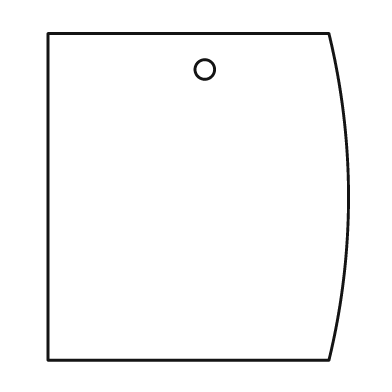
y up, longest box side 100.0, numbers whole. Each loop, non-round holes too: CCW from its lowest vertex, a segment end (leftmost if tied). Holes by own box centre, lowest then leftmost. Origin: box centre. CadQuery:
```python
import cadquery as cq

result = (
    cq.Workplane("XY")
    .moveTo(-46.0, -50.0)
    .lineTo(40.0, -50.0)
    .threePointArc((46.0, 0.0), (40.0, 50.0))
    .lineTo(-46.0, 50.0)
    .close()
    .moveTo(2.0, 39.0)
    .circle(3.0)
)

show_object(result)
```